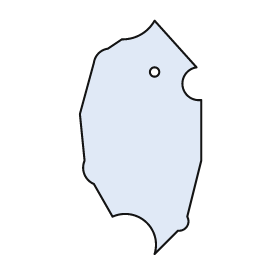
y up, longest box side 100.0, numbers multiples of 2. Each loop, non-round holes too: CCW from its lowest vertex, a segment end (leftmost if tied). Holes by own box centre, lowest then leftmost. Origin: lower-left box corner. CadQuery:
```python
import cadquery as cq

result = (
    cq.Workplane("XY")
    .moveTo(32.0, 0.0)
    .lineTo(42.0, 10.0)
    .threePointArc((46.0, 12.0), (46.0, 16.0))
    .lineTo(52.0, 40.0)
    .lineTo(52.0, 66.0)
    .threePointArc((44.0, 72.0), (50.0, 80.0))
    .lineTo(32.0, 100.0)
    .threePointArc((26.0, 94.0), (18.0, 92.0))
    .lineTo(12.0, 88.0)
    .threePointArc((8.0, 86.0), (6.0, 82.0))
    .lineTo(0.0, 60.0)
    .lineTo(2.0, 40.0)
    .threePointArc((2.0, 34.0), (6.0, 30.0))
    .lineTo(14.0, 16.0)
    .threePointArc((28.0, 14.0), (32.0, 0.0))
    .close()
    .moveTo(32.0, 78.0)
    .circle(2.0)
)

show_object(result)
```